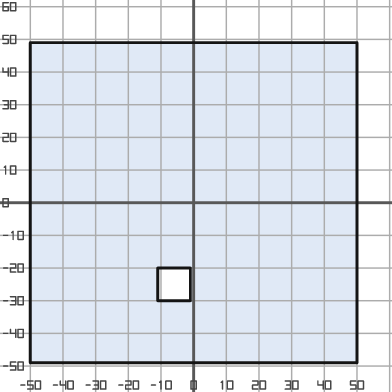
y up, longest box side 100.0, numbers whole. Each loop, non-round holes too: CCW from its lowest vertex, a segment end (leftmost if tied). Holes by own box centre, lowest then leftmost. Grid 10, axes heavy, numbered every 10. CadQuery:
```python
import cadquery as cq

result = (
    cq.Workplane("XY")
    .moveTo(-50.0, -49.0)
    .lineTo(50.0, -49.0)
    .lineTo(50.0, 49.0)
    .lineTo(-50.0, 49.0)
    .close()
    .moveTo(-11.0, -30.0)
    .lineTo(-1.0, -30.0)
    .lineTo(-1.0, -20.0)
    .lineTo(-11.0, -20.0)
    .close()
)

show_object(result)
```